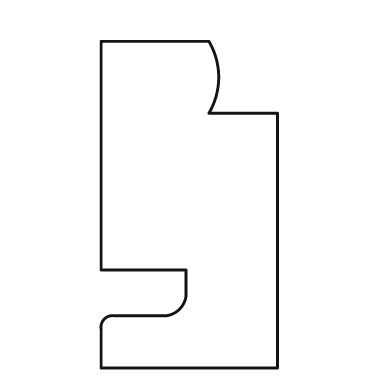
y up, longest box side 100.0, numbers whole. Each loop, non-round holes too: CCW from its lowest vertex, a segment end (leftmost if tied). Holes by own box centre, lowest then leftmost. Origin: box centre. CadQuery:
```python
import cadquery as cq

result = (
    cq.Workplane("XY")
    .moveTo(-27.0, -50.0)
    .lineTo(27.0, -50.0)
    .lineTo(27.0, 28.0)
    .lineTo(6.0, 28.0)
    .threePointArc((9.0, 39.0), (6.0, 50.0))
    .lineTo(-27.0, 50.0)
    .lineTo(-27.0, -20.0)
    .lineTo(-1.0, -20.0)
    .lineTo(-1.0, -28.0)
    .threePointArc((-3.0, -32.0), (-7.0, -34.0))
    .lineTo(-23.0, -34.0)
    .threePointArc((-26.0, -35.0), (-27.0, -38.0))
    .close()
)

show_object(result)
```